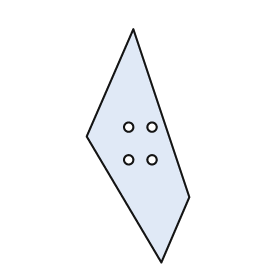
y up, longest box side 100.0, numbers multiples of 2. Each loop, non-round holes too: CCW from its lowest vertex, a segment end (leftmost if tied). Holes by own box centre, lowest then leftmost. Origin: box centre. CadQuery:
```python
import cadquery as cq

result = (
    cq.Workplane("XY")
    .moveTo(10.0, -50.0)
    .lineTo(22.0, -22.0)
    .lineTo(-2.0, 50.0)
    .lineTo(-22.0, 4.0)
    .close()
    .moveTo(-4.0, -6.0)
    .circle(2.0)
    .moveTo(6.0, -6.0)
    .circle(2.0)
    .moveTo(-4.0, 8.0)
    .circle(2.0)
    .moveTo(6.0, 8.0)
    .circle(2.0)
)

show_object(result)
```